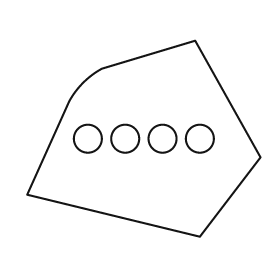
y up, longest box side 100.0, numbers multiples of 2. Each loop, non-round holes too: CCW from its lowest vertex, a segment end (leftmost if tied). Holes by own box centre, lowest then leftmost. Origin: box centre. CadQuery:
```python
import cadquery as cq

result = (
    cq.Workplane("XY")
    .moveTo(24.0, -42.0)
    .lineTo(50.0, -8.0)
    .lineTo(22.0, 42.0)
    .lineTo(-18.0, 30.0)
    .threePointArc((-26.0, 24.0), (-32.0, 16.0))
    .lineTo(-50.0, -24.0)
    .close()
    .moveTo(-24.0, 0.0)
    .circle(6.0)
    .moveTo(-8.0, 0.0)
    .circle(6.0)
    .moveTo(8.0, 0.0)
    .circle(6.0)
    .moveTo(24.0, 0.0)
    .circle(6.0)
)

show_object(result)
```